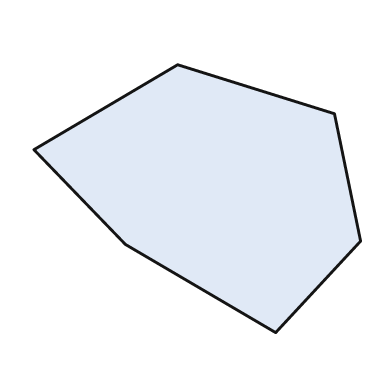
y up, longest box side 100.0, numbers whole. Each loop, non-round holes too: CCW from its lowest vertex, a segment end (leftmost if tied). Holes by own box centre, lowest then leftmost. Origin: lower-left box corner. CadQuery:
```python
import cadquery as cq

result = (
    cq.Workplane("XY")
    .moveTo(74.0, 0.0)
    .lineTo(100.0, 28.0)
    .lineTo(92.0, 67.0)
    .lineTo(44.0, 82.0)
    .lineTo(0.0, 56.0)
    .lineTo(28.0, 27.0)
    .close()
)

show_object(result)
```